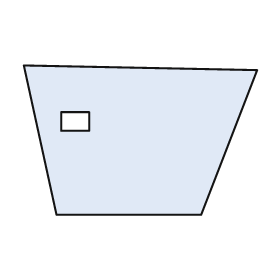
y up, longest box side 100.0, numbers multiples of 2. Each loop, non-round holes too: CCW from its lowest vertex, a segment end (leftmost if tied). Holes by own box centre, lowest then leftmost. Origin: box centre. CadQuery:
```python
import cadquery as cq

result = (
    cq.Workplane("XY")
    .moveTo(-36.0, -32.0)
    .lineTo(26.0, -32.0)
    .lineTo(50.0, 30.0)
    .lineTo(-50.0, 32.0)
    .close()
    .moveTo(-34.0, 4.0)
    .lineTo(-22.0, 4.0)
    .lineTo(-22.0, 12.0)
    .lineTo(-34.0, 12.0)
    .close()
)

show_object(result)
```